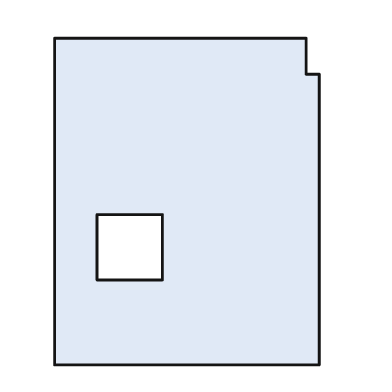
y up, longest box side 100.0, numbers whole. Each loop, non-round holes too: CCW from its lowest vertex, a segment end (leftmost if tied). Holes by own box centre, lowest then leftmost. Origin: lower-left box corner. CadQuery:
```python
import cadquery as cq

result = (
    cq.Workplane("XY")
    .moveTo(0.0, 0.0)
    .lineTo(81.0, 0.0)
    .lineTo(81.0, 89.0)
    .lineTo(77.0, 89.0)
    .lineTo(77.0, 100.0)
    .lineTo(0.0, 100.0)
    .close()
    .moveTo(13.0, 26.0)
    .lineTo(33.0, 26.0)
    .lineTo(33.0, 46.0)
    .lineTo(13.0, 46.0)
    .close()
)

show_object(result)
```